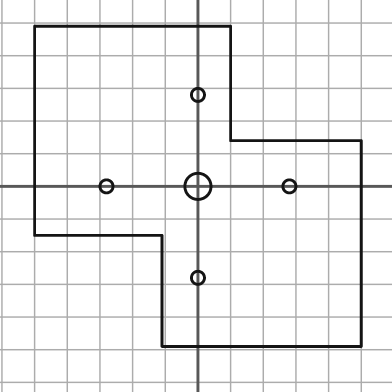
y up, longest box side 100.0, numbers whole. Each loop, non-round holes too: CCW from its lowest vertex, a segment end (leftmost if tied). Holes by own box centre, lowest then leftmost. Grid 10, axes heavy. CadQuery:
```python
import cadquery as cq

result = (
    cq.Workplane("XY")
    .moveTo(-11.0, -49.0)
    .lineTo(50.0, -49.0)
    .lineTo(50.0, 14.0)
    .lineTo(10.0, 14.0)
    .lineTo(10.0, 49.0)
    .lineTo(-50.0, 49.0)
    .lineTo(-50.0, -15.0)
    .lineTo(-11.0, -15.0)
    .close()
    .moveTo(0.0, -28.0)
    .circle(2.0)
    .moveTo(-28.0, 0.0)
    .circle(2.0)
    .moveTo(0.0, 0.0)
    .circle(4.0)
    .moveTo(28.0, 0.0)
    .circle(2.0)
    .moveTo(0.0, 28.0)
    .circle(2.0)
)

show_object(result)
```